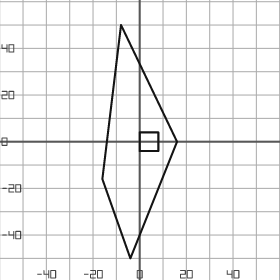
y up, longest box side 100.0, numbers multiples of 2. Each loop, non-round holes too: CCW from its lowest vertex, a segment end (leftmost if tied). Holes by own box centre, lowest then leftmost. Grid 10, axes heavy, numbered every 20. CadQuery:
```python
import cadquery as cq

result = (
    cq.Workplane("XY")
    .moveTo(-4.0, -50.0)
    .lineTo(16.0, 0.0)
    .lineTo(-8.0, 50.0)
    .lineTo(-16.0, -16.0)
    .close()
    .moveTo(0.0, -4.0)
    .lineTo(8.0, -4.0)
    .lineTo(8.0, 4.0)
    .lineTo(0.0, 4.0)
    .close()
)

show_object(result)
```